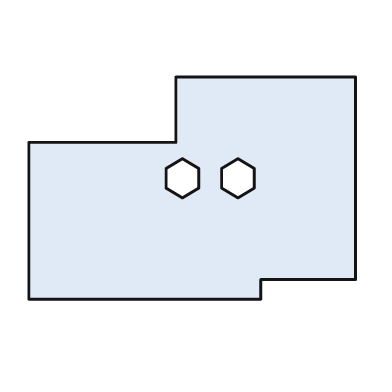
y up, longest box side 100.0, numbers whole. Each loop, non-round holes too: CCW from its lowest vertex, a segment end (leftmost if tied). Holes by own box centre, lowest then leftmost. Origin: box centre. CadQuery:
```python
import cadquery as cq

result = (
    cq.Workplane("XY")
    .moveTo(-50.0, -34.0)
    .lineTo(21.0, -34.0)
    .lineTo(21.0, -28.0)
    .lineTo(50.0, -28.0)
    .lineTo(50.0, 34.0)
    .lineTo(-5.0, 34.0)
    .lineTo(-5.0, 14.0)
    .lineTo(-50.0, 14.0)
    .close()
    .moveTo(-3.0, -3.0)
    .lineTo(2.0, 0.0)
    .lineTo(2.0, 6.0)
    .lineTo(-3.0, 9.0)
    .lineTo(-8.0, 6.0)
    .lineTo(-8.0, 0.0)
    .close()
    .moveTo(14.0, -3.0)
    .lineTo(19.0, 0.0)
    .lineTo(19.0, 6.0)
    .lineTo(14.0, 9.0)
    .lineTo(9.0, 6.0)
    .lineTo(9.0, 0.0)
    .close()
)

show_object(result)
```